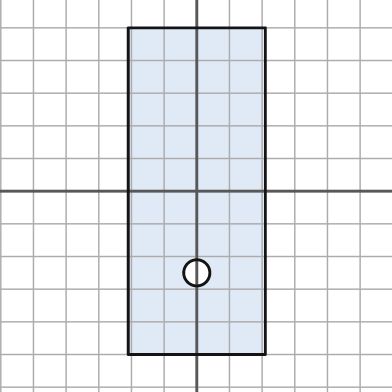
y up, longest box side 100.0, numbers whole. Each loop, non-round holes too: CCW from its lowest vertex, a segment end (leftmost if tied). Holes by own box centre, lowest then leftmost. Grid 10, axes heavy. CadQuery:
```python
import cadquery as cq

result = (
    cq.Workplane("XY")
    .moveTo(-21.0, -50.0)
    .lineTo(21.0, -50.0)
    .lineTo(21.0, 50.0)
    .lineTo(-21.0, 50.0)
    .close()
    .moveTo(0.0, -25.0)
    .circle(4.0)
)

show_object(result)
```